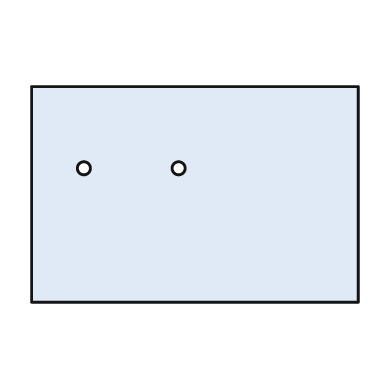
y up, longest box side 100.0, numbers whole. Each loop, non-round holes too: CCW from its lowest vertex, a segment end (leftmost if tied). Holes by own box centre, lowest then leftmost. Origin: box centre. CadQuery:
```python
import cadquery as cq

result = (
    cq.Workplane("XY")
    .moveTo(-50.0, -33.0)
    .lineTo(50.0, -33.0)
    .lineTo(50.0, 33.0)
    .lineTo(-50.0, 33.0)
    .close()
    .moveTo(-34.0, 8.0)
    .circle(2.0)
    .moveTo(-5.0, 8.0)
    .circle(2.0)
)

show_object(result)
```